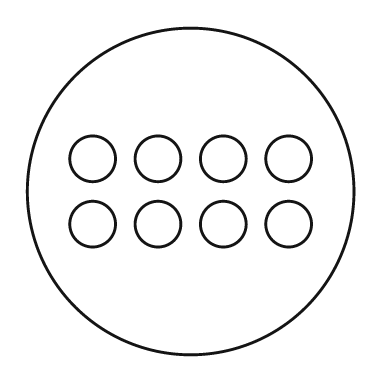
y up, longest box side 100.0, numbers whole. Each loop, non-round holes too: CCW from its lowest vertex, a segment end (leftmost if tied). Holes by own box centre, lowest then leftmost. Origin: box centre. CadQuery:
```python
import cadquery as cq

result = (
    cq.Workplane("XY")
    .moveTo(0.0, 0.0)
    .circle(50.0)
    .moveTo(-30.0, -10.0)
    .circle(7.0)
    .moveTo(-10.0, -10.0)
    .circle(7.0)
    .moveTo(10.0, -10.0)
    .circle(7.0)
    .moveTo(30.0, -10.0)
    .circle(7.0)
    .moveTo(-30.0, 10.0)
    .circle(7.0)
    .moveTo(-10.0, 10.0)
    .circle(7.0)
    .moveTo(10.0, 10.0)
    .circle(7.0)
    .moveTo(30.0, 10.0)
    .circle(7.0)
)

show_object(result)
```